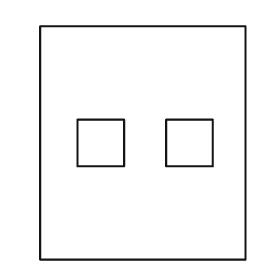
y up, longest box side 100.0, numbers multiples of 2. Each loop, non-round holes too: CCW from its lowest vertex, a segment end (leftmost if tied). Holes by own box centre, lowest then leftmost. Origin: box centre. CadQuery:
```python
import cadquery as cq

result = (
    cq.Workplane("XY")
    .moveTo(-44.0, -50.0)
    .lineTo(44.0, -50.0)
    .lineTo(44.0, 50.0)
    .lineTo(-44.0, 50.0)
    .close()
    .moveTo(-28.0, -10.0)
    .lineTo(-8.0, -10.0)
    .lineTo(-8.0, 10.0)
    .lineTo(-28.0, 10.0)
    .close()
    .moveTo(10.0, -10.0)
    .lineTo(30.0, -10.0)
    .lineTo(30.0, 10.0)
    .lineTo(10.0, 10.0)
    .close()
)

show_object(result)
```